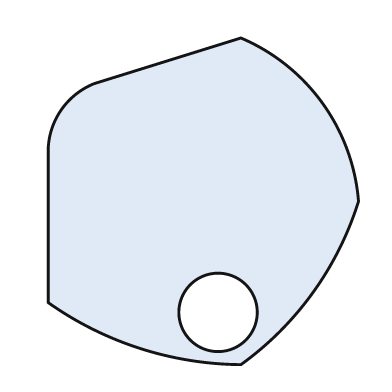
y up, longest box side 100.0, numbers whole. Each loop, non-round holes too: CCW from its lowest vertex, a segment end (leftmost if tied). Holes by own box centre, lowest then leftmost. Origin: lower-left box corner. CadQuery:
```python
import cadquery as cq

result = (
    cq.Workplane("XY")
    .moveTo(59.0, 0.0)
    .threePointArc((81.0, 22.0), (95.0, 50.0))
    .threePointArc((84.0, 80.0), (59.0, 100.0))
    .lineTo(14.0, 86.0)
    .threePointArc((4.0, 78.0), (0.0, 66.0))
    .lineTo(0.0, 19.0)
    .threePointArc((28.0, 5.0), (59.0, 0.0))
    .close()
    .moveTo(52.0, 16.0)
    .circle(12.0)
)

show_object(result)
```